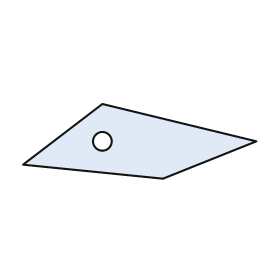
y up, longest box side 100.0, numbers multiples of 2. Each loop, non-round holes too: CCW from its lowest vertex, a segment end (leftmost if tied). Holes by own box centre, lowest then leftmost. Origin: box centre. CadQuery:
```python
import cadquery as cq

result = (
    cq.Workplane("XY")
    .moveTo(10.0, -16.0)
    .lineTo(50.0, 0.0)
    .lineTo(-16.0, 16.0)
    .lineTo(-50.0, -10.0)
    .close()
    .moveTo(-16.0, 0.0)
    .circle(4.0)
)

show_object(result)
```